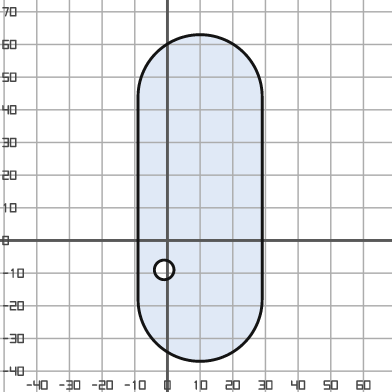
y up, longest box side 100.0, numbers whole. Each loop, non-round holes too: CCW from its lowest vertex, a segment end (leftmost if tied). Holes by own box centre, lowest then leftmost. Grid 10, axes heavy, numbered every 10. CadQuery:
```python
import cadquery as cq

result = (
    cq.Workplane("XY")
    .moveTo(-9.0, -18.0)
    .threePointArc((10.0, -37.0), (29.0, -18.0))
    .lineTo(29.0, 44.0)
    .threePointArc((10.0, 63.0), (-9.0, 44.0))
    .close()
    .moveTo(-1.0, -9.0)
    .circle(3.0)
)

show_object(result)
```